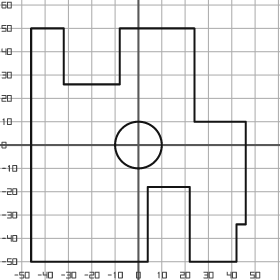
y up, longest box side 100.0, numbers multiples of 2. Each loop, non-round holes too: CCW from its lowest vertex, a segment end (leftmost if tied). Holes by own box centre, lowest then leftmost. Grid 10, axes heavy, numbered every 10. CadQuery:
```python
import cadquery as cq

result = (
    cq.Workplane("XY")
    .moveTo(-46.0, -50.0)
    .lineTo(4.0, -50.0)
    .lineTo(4.0, -18.0)
    .lineTo(22.0, -18.0)
    .lineTo(22.0, -50.0)
    .lineTo(42.0, -50.0)
    .lineTo(42.0, -34.0)
    .lineTo(46.0, -34.0)
    .lineTo(46.0, 10.0)
    .lineTo(24.0, 10.0)
    .lineTo(24.0, 50.0)
    .lineTo(-8.0, 50.0)
    .lineTo(-8.0, 26.0)
    .lineTo(-32.0, 26.0)
    .lineTo(-32.0, 50.0)
    .lineTo(-46.0, 50.0)
    .close()
    .moveTo(0.0, 0.0)
    .circle(10.0)
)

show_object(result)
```